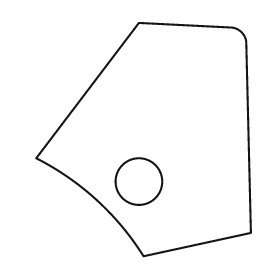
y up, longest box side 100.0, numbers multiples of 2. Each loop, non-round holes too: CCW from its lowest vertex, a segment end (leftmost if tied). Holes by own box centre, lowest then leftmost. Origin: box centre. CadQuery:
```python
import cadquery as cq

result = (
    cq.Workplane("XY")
    .moveTo(0.0, -50.0)
    .lineTo(46.0, -40.0)
    .lineTo(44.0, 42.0)
    .threePointArc((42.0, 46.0), (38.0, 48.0))
    .lineTo(-2.0, 50.0)
    .lineTo(-46.0, -8.0)
    .threePointArc((-20.0, -26.0), (0.0, -50.0))
    .close()
    .moveTo(-2.0, -18.0)
    .circle(10.0)
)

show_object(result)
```